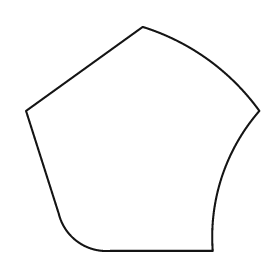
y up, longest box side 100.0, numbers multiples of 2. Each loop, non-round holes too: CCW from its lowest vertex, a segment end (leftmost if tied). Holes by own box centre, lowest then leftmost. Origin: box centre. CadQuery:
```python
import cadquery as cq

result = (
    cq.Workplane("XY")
    .moveTo(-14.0, -48.0)
    .lineTo(30.0, -48.0)
    .threePointArc((34.0, -16.0), (50.0, 12.0))
    .threePointArc((28.0, 34.0), (0.0, 48.0))
    .lineTo(-50.0, 12.0)
    .lineTo(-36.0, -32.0)
    .threePointArc((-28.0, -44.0), (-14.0, -48.0))
    .close()
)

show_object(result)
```